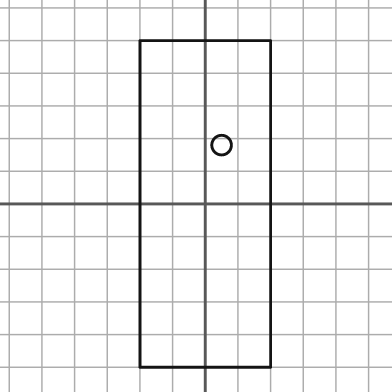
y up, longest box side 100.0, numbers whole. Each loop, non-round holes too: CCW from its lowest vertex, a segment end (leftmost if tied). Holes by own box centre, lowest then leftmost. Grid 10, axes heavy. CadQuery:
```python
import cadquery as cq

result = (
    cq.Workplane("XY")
    .moveTo(-20.0, -50.0)
    .lineTo(20.0, -50.0)
    .lineTo(20.0, 50.0)
    .lineTo(-20.0, 50.0)
    .close()
    .moveTo(5.0, 18.0)
    .circle(3.0)
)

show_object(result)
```